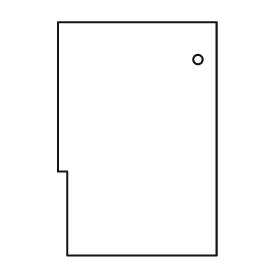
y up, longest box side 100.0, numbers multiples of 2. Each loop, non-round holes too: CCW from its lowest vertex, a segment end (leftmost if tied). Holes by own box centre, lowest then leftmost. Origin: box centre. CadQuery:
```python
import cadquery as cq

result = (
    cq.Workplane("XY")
    .moveTo(-30.0, -50.0)
    .lineTo(34.0, -50.0)
    .lineTo(34.0, 50.0)
    .lineTo(-34.0, 50.0)
    .lineTo(-34.0, -14.0)
    .lineTo(-30.0, -14.0)
    .close()
    .moveTo(26.0, 34.0)
    .circle(2.0)
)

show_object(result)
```